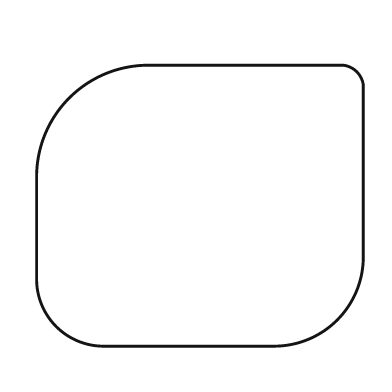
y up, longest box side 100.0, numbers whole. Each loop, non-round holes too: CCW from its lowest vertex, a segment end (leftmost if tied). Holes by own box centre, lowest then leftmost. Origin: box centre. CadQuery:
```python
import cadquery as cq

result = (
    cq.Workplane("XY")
    .moveTo(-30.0, -43.0)
    .lineTo(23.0, -43.0)
    .threePointArc((42.0, -35.0), (50.0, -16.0))
    .lineTo(50.0, 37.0)
    .threePointArc((48.0, 41.0), (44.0, 43.0))
    .lineTo(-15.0, 43.0)
    .threePointArc((-40.0, 33.0), (-50.0, 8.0))
    .lineTo(-50.0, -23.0)
    .threePointArc((-44.0, -37.0), (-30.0, -43.0))
    .close()
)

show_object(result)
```